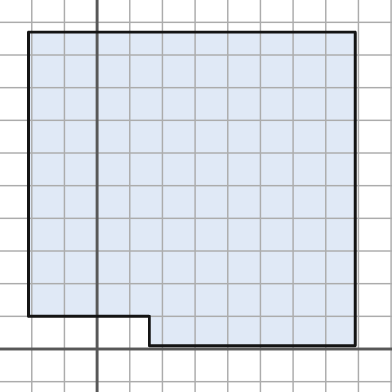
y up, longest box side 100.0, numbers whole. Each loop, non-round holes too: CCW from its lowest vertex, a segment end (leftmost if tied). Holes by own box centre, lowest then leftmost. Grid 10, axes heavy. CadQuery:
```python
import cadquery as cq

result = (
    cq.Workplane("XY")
    .moveTo(16.0, 1.0)
    .lineTo(79.0, 1.0)
    .lineTo(79.0, 97.0)
    .lineTo(-21.0, 97.0)
    .lineTo(-21.0, 10.0)
    .lineTo(16.0, 10.0)
    .close()
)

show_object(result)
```